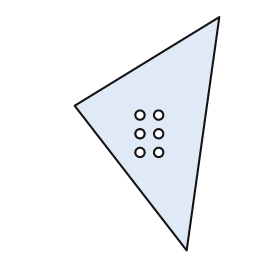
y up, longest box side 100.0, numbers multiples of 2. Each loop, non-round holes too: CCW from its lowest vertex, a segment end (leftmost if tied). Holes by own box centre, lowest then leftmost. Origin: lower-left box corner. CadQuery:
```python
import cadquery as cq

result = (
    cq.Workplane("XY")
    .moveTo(48.0, 0.0)
    .lineTo(62.0, 100.0)
    .lineTo(0.0, 62.0)
    .close()
    .moveTo(28.0, 42.0)
    .circle(2.0)
    .moveTo(36.0, 42.0)
    .circle(2.0)
    .moveTo(28.0, 50.0)
    .circle(2.0)
    .moveTo(36.0, 50.0)
    .circle(2.0)
    .moveTo(28.0, 58.0)
    .circle(2.0)
    .moveTo(36.0, 58.0)
    .circle(2.0)
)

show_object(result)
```